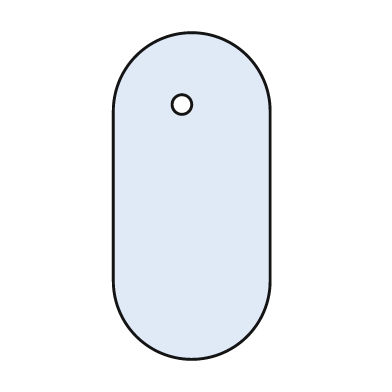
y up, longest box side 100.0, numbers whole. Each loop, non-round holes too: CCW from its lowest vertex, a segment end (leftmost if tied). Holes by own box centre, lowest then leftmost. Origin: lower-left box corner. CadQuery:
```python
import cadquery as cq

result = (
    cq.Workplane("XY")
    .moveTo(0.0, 24.0)
    .threePointArc((24.0, 0.0), (48.0, 24.0))
    .lineTo(48.0, 76.0)
    .threePointArc((24.0, 100.0), (0.0, 76.0))
    .close()
    .moveTo(21.0, 78.0)
    .circle(3.0)
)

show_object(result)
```